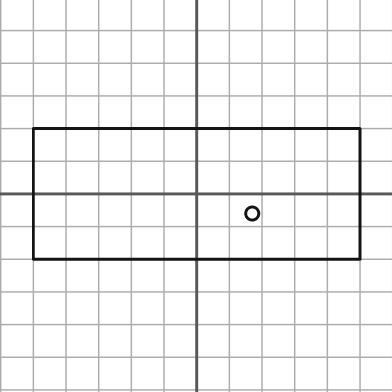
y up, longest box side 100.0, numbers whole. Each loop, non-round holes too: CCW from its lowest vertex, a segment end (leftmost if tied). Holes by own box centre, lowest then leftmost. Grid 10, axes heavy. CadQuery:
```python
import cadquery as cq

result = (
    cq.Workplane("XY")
    .moveTo(-50.0, -20.0)
    .lineTo(50.0, -20.0)
    .lineTo(50.0, 20.0)
    .lineTo(-50.0, 20.0)
    .close()
    .moveTo(17.0, -6.0)
    .circle(2.0)
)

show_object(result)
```